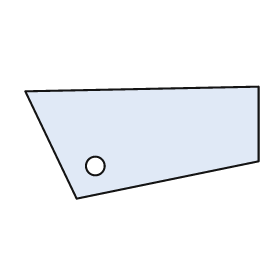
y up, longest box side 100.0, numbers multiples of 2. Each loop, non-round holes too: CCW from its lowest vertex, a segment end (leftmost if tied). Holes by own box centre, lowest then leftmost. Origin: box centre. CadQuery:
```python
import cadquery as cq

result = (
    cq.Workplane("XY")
    .moveTo(-28.0, -24.0)
    .lineTo(50.0, -8.0)
    .lineTo(50.0, 24.0)
    .lineTo(-50.0, 22.0)
    .close()
    .moveTo(-20.0, -10.0)
    .circle(4.0)
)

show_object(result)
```